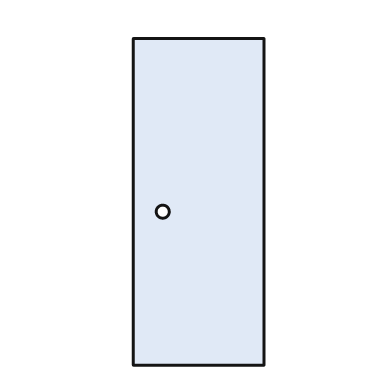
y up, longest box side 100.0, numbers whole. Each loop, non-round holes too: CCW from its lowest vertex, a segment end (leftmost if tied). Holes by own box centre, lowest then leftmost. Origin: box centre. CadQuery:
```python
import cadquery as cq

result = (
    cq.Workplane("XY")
    .moveTo(-20.0, -50.0)
    .lineTo(20.0, -50.0)
    .lineTo(20.0, 50.0)
    .lineTo(-20.0, 50.0)
    .close()
    .moveTo(-11.0, -3.0)
    .circle(2.0)
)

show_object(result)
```